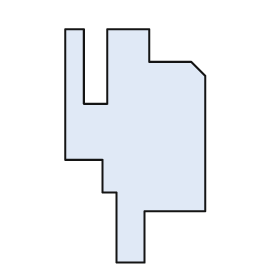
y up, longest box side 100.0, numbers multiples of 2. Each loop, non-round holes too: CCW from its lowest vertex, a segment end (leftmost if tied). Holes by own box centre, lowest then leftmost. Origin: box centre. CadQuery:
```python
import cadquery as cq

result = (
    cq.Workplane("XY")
    .moveTo(-8.0, -50.0)
    .lineTo(4.0, -50.0)
    .lineTo(4.0, -28.0)
    .lineTo(30.0, -28.0)
    .lineTo(30.0, 30.0)
    .lineTo(24.0, 36.0)
    .lineTo(6.0, 36.0)
    .lineTo(6.0, 50.0)
    .lineTo(-12.0, 50.0)
    .lineTo(-12.0, 18.0)
    .lineTo(-22.0, 18.0)
    .lineTo(-22.0, 50.0)
    .lineTo(-30.0, 50.0)
    .lineTo(-30.0, -6.0)
    .lineTo(-14.0, -6.0)
    .lineTo(-14.0, -20.0)
    .lineTo(-8.0, -20.0)
    .close()
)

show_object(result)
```